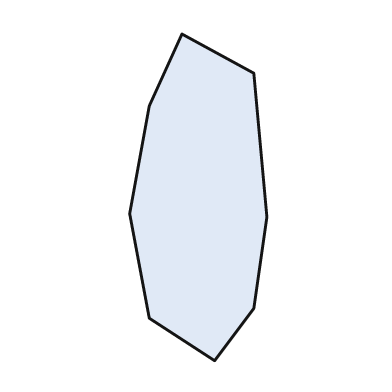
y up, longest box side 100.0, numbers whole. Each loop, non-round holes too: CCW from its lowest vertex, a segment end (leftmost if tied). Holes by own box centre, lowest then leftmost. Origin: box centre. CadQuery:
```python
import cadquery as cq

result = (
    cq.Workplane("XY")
    .moveTo(5.0, -50.0)
    .lineTo(17.0, -34.0)
    .lineTo(21.0, -6.0)
    .lineTo(17.0, 38.0)
    .lineTo(-5.0, 50.0)
    .lineTo(-15.0, 28.0)
    .lineTo(-21.0, -5.0)
    .lineTo(-15.0, -37.0)
    .close()
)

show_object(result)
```